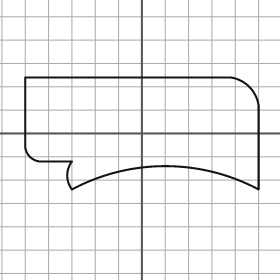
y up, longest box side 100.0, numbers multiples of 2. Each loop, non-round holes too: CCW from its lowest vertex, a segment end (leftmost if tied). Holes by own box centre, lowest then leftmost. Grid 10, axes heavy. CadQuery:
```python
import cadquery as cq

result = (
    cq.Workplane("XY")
    .moveTo(-30.0, -24.0)
    .threePointArc((10.0, -14.0), (50.0, -24.0))
    .lineTo(50.0, 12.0)
    .threePointArc((46.0, 20.0), (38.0, 24.0))
    .lineTo(-50.0, 24.0)
    .lineTo(-50.0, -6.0)
    .threePointArc((-48.0, -10.0), (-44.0, -12.0))
    .lineTo(-30.0, -12.0)
    .threePointArc((-32.0, -18.0), (-30.0, -24.0))
    .close()
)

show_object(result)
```